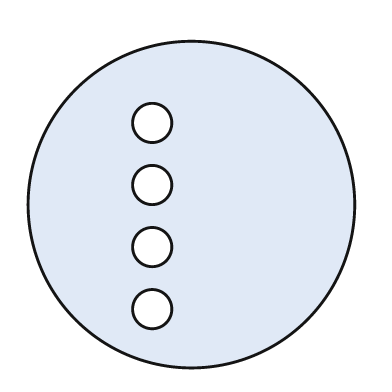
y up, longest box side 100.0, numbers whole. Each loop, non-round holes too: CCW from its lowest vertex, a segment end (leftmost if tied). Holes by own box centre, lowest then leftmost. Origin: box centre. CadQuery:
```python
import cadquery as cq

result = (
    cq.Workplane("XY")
    .moveTo(0.0, 0.0)
    .circle(50.0)
    .moveTo(-12.0, -32.0)
    .circle(6.0)
    .moveTo(-12.0, -13.0)
    .circle(6.0)
    .moveTo(-12.0, 6.0)
    .circle(6.0)
    .moveTo(-12.0, 25.0)
    .circle(6.0)
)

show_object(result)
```